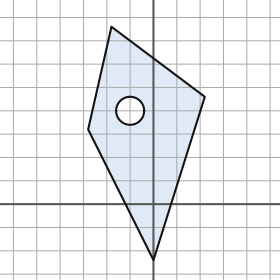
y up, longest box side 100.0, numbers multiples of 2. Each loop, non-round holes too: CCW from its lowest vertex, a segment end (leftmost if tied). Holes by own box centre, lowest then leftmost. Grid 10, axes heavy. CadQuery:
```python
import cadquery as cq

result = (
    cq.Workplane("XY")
    .moveTo(0.0, -24.0)
    .lineTo(22.0, 46.0)
    .lineTo(-18.0, 76.0)
    .lineTo(-28.0, 32.0)
    .close()
    .moveTo(-10.0, 40.0)
    .circle(6.0)
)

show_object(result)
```